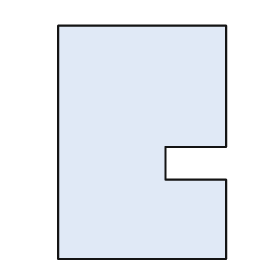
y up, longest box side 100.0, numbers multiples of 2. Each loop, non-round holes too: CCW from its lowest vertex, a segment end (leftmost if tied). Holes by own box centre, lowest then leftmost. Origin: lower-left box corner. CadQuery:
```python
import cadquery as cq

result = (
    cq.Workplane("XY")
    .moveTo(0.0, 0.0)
    .lineTo(72.0, 0.0)
    .lineTo(72.0, 34.0)
    .lineTo(46.0, 34.0)
    .lineTo(46.0, 48.0)
    .lineTo(72.0, 48.0)
    .lineTo(72.0, 100.0)
    .lineTo(0.0, 100.0)
    .close()
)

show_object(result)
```